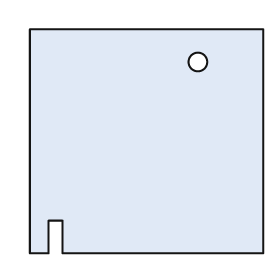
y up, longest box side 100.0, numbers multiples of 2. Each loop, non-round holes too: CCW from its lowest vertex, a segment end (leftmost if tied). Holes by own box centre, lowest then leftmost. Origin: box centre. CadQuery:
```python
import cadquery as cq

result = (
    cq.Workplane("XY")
    .moveTo(-50.0, -48.0)
    .lineTo(-42.0, -48.0)
    .lineTo(-42.0, -34.0)
    .lineTo(-36.0, -34.0)
    .lineTo(-36.0, -48.0)
    .lineTo(50.0, -48.0)
    .lineTo(50.0, 48.0)
    .lineTo(-50.0, 48.0)
    .close()
    .moveTo(22.0, 34.0)
    .circle(4.0)
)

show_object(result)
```